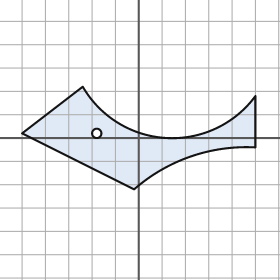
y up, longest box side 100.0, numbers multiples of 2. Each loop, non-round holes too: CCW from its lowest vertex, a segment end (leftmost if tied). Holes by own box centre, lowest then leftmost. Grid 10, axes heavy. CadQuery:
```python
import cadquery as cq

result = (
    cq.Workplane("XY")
    .moveTo(-2.0, -22.0)
    .threePointArc((22.0, -8.0), (50.0, -4.0))
    .lineTo(50.0, 18.0)
    .threePointArc((12.0, 0.0), (-24.0, 22.0))
    .lineTo(-50.0, 2.0)
    .close()
    .moveTo(-18.0, 2.0)
    .circle(2.0)
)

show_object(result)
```